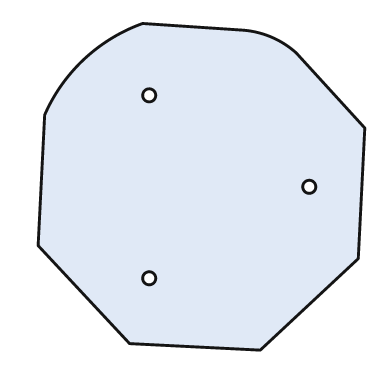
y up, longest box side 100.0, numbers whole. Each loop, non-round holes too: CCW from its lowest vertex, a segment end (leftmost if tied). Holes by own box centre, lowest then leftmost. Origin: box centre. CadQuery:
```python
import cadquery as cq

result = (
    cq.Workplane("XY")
    .moveTo(18.0, -50.0)
    .lineTo(48.0, -22.0)
    .lineTo(50.0, 18.0)
    .lineTo(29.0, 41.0)
    .threePointArc((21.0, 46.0), (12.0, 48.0))
    .lineTo(-18.0, 50.0)
    .threePointArc((-36.0, 39.0), (-48.0, 22.0))
    .lineTo(-50.0, -18.0)
    .lineTo(-22.0, -48.0)
    .close()
    .moveTo(-16.0, -28.0)
    .circle(2.0)
    .moveTo(33.0, 0.0)
    .circle(2.0)
    .moveTo(-16.0, 28.0)
    .circle(2.0)
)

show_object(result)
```